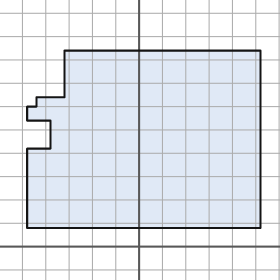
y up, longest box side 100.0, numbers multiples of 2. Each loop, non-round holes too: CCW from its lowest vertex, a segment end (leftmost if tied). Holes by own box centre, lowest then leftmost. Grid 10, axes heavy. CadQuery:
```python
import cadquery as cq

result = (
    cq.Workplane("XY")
    .moveTo(-48.0, 8.0)
    .lineTo(52.0, 8.0)
    .lineTo(52.0, 84.0)
    .lineTo(-32.0, 84.0)
    .lineTo(-32.0, 64.0)
    .lineTo(-44.0, 64.0)
    .lineTo(-44.0, 60.0)
    .lineTo(-48.0, 60.0)
    .lineTo(-48.0, 54.0)
    .lineTo(-38.0, 54.0)
    .lineTo(-38.0, 42.0)
    .lineTo(-48.0, 42.0)
    .close()
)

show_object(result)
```